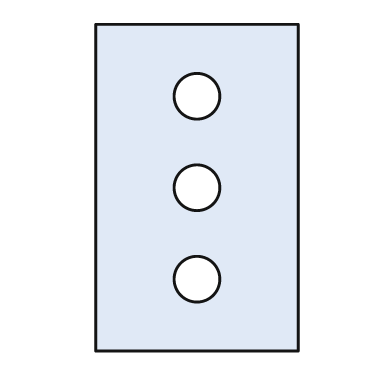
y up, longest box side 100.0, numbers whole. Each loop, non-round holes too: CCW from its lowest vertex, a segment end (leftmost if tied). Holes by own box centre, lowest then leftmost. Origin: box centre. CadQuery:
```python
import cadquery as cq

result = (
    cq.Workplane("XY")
    .moveTo(-31.0, -50.0)
    .lineTo(31.0, -50.0)
    .lineTo(31.0, 50.0)
    .lineTo(-31.0, 50.0)
    .close()
    .moveTo(0.0, -28.0)
    .circle(7.0)
    .moveTo(0.0, 0.0)
    .circle(7.0)
    .moveTo(0.0, 28.0)
    .circle(7.0)
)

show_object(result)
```